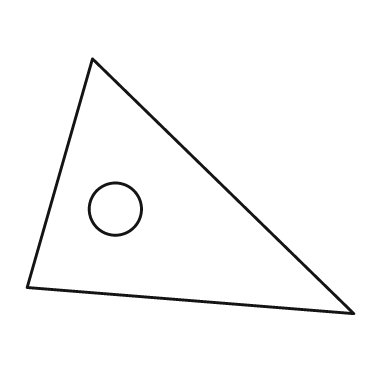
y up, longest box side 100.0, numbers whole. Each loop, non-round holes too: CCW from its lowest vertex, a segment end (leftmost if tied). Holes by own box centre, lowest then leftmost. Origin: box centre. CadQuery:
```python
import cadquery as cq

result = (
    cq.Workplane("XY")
    .moveTo(50.0, -39.0)
    .lineTo(-30.0, 39.0)
    .lineTo(-50.0, -31.0)
    .close()
    .moveTo(-23.0, -7.0)
    .circle(8.0)
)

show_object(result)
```